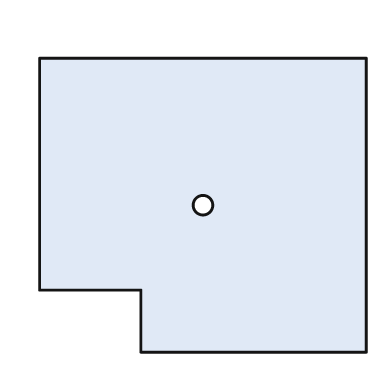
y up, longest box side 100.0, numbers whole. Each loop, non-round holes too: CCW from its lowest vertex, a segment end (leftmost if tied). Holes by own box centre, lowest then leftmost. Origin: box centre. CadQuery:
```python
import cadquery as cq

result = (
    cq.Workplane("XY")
    .moveTo(-19.0, -45.0)
    .lineTo(50.0, -45.0)
    .lineTo(50.0, 45.0)
    .lineTo(-50.0, 45.0)
    .lineTo(-50.0, -26.0)
    .lineTo(-19.0, -26.0)
    .close()
    .moveTo(0.0, 0.0)
    .circle(3.0)
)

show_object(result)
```